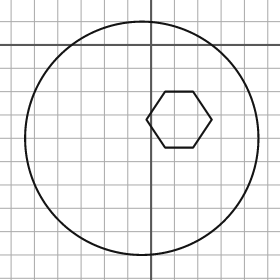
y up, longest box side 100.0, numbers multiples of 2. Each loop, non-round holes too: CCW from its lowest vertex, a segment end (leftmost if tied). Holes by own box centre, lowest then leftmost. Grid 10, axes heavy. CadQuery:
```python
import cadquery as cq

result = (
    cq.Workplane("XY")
    .moveTo(-4.0, -40.0)
    .circle(50.0)
    .moveTo(6.0, -44.0)
    .lineTo(18.0, -44.0)
    .lineTo(26.0, -32.0)
    .lineTo(18.0, -20.0)
    .lineTo(6.0, -20.0)
    .lineTo(-2.0, -32.0)
    .close()
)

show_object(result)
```